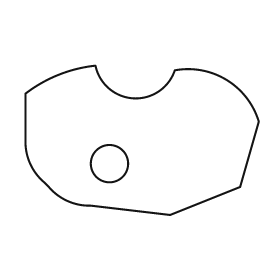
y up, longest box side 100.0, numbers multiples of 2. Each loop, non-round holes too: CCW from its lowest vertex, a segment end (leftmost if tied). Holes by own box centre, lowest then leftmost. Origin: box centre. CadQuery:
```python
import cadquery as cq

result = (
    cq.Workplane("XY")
    .moveTo(12.0, -32.0)
    .lineTo(42.0, -20.0)
    .lineTo(50.0, 8.0)
    .threePointArc((36.0, 26.0), (14.0, 30.0))
    .threePointArc((-4.0, 18.0), (-20.0, 32.0))
    .threePointArc((-36.0, 28.0), (-50.0, 20.0))
    .lineTo(-50.0, 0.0)
    .threePointArc((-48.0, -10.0), (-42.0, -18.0))
    .lineTo(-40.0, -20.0)
    .threePointArc((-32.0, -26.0), (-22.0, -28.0))
    .close()
    .moveTo(-14.0, -10.0)
    .circle(8.0)
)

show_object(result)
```